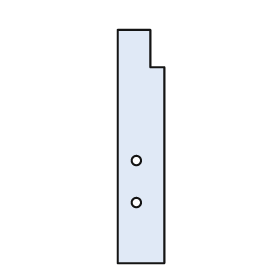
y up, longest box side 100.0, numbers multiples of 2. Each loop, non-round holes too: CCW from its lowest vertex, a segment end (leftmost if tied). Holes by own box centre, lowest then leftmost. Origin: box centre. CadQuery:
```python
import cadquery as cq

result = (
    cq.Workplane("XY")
    .moveTo(-10.0, -50.0)
    .lineTo(10.0, -50.0)
    .lineTo(10.0, 34.0)
    .lineTo(4.0, 34.0)
    .lineTo(4.0, 50.0)
    .lineTo(-10.0, 50.0)
    .close()
    .moveTo(-2.0, -24.0)
    .circle(2.0)
    .moveTo(-2.0, -6.0)
    .circle(2.0)
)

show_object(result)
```